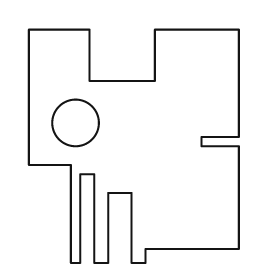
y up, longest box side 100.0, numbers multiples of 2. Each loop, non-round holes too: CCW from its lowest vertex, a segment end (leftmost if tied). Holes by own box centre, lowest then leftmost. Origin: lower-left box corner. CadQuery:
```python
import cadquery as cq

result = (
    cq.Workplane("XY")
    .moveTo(18.0, 0.0)
    .lineTo(22.0, 0.0)
    .lineTo(22.0, 38.0)
    .lineTo(28.0, 38.0)
    .lineTo(28.0, 0.0)
    .lineTo(34.0, 0.0)
    .lineTo(34.0, 30.0)
    .lineTo(44.0, 30.0)
    .lineTo(44.0, 0.0)
    .lineTo(50.0, 0.0)
    .lineTo(50.0, 6.0)
    .lineTo(90.0, 6.0)
    .lineTo(90.0, 50.0)
    .lineTo(74.0, 50.0)
    .lineTo(74.0, 54.0)
    .lineTo(90.0, 54.0)
    .lineTo(90.0, 100.0)
    .lineTo(54.0, 100.0)
    .lineTo(54.0, 78.0)
    .lineTo(26.0, 78.0)
    .lineTo(26.0, 100.0)
    .lineTo(0.0, 100.0)
    .lineTo(0.0, 42.0)
    .lineTo(18.0, 42.0)
    .close()
    .moveTo(20.0, 60.0)
    .circle(10.0)
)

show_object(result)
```